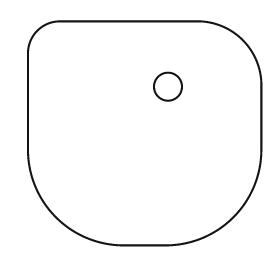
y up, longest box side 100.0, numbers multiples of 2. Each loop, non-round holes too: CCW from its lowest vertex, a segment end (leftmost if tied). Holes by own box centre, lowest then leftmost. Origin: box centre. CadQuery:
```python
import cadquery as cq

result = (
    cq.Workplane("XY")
    .moveTo(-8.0, -48.0)
    .lineTo(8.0, -48.0)
    .threePointArc((38.0, -36.0), (50.0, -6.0))
    .lineTo(50.0, 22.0)
    .threePointArc((42.0, 40.0), (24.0, 48.0))
    .lineTo(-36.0, 48.0)
    .threePointArc((-46.0, 44.0), (-50.0, 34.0))
    .lineTo(-50.0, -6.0)
    .threePointArc((-38.0, -36.0), (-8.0, -48.0))
    .close()
    .moveTo(10.0, 20.0)
    .circle(6.0)
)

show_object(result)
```